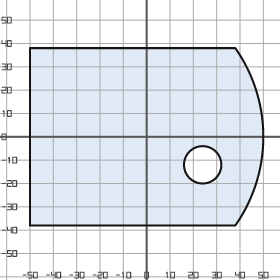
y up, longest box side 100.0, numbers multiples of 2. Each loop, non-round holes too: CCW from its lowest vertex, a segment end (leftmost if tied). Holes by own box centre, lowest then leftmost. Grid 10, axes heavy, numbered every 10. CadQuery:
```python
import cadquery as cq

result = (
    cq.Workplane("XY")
    .moveTo(-50.0, -38.0)
    .lineTo(38.0, -38.0)
    .threePointArc((50.0, 0.0), (38.0, 38.0))
    .lineTo(-50.0, 38.0)
    .close()
    .moveTo(24.0, -12.0)
    .circle(8.0)
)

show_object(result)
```